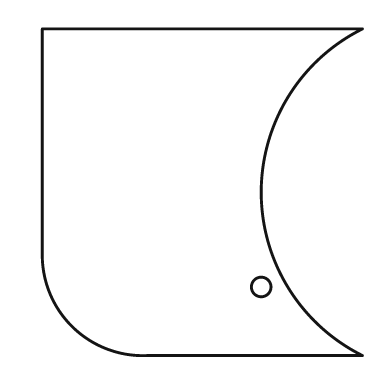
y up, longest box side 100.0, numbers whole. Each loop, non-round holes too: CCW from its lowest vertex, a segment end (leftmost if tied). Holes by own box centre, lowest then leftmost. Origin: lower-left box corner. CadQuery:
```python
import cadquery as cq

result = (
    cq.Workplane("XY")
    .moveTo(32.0, 0.0)
    .lineTo(98.0, 0.0)
    .threePointArc((67.0, 50.0), (98.0, 100.0))
    .lineTo(0.0, 100.0)
    .lineTo(0.0, 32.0)
    .threePointArc((9.0, 9.0), (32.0, 0.0))
    .close()
    .moveTo(67.0, 21.0)
    .circle(3.0)
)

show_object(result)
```